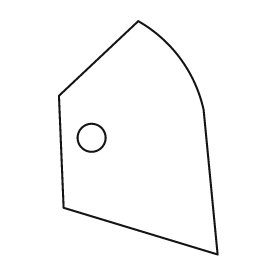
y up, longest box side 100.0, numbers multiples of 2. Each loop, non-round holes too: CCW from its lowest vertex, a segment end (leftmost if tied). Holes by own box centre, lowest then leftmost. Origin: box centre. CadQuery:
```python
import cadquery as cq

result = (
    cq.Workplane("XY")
    .moveTo(34.0, -50.0)
    .lineTo(28.0, 12.0)
    .threePointArc((18.0, 34.0), (0.0, 50.0))
    .lineTo(-34.0, 18.0)
    .lineTo(-32.0, -30.0)
    .close()
    .moveTo(-20.0, 0.0)
    .circle(6.0)
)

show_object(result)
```